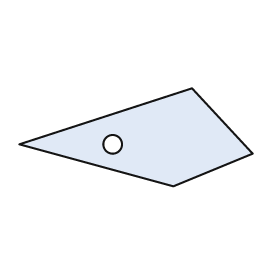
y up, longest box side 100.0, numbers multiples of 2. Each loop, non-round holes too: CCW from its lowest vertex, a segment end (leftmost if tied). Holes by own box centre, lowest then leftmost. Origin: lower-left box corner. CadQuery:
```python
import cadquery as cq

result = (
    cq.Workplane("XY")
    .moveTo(66.0, 0.0)
    .lineTo(100.0, 14.0)
    .lineTo(74.0, 42.0)
    .lineTo(0.0, 18.0)
    .close()
    .moveTo(40.0, 18.0)
    .circle(4.0)
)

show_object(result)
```